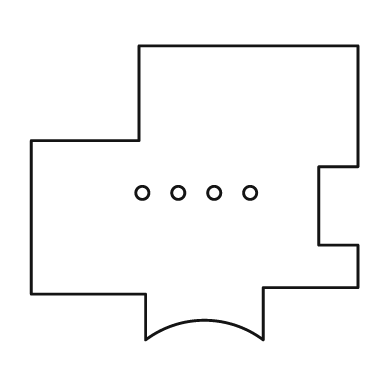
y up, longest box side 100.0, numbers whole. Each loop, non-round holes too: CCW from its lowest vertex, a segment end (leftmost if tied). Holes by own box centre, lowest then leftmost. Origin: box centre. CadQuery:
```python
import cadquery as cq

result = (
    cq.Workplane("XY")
    .moveTo(-15.0, -45.0)
    .threePointArc((3.0, -39.0), (21.0, -45.0))
    .lineTo(21.0, -29.0)
    .lineTo(50.0, -29.0)
    .lineTo(50.0, -16.0)
    .lineTo(38.0, -16.0)
    .lineTo(38.0, 8.0)
    .lineTo(50.0, 8.0)
    .lineTo(50.0, 45.0)
    .lineTo(-17.0, 45.0)
    .lineTo(-17.0, 16.0)
    .lineTo(-50.0, 16.0)
    .lineTo(-50.0, -31.0)
    .lineTo(-15.0, -31.0)
    .close()
    .moveTo(-16.0, 0.0)
    .circle(2.0)
    .moveTo(-5.0, 0.0)
    .circle(2.0)
    .moveTo(6.0, 0.0)
    .circle(2.0)
    .moveTo(17.0, 0.0)
    .circle(2.0)
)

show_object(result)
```